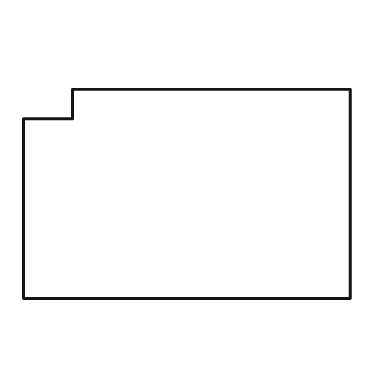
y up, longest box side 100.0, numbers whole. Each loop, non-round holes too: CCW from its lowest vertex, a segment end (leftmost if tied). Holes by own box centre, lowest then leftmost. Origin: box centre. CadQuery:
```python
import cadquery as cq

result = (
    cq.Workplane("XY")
    .moveTo(-50.0, -32.0)
    .lineTo(50.0, -32.0)
    .lineTo(50.0, 32.0)
    .lineTo(-35.0, 32.0)
    .lineTo(-35.0, 23.0)
    .lineTo(-50.0, 23.0)
    .close()
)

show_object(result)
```